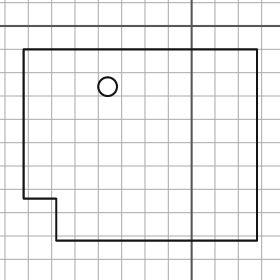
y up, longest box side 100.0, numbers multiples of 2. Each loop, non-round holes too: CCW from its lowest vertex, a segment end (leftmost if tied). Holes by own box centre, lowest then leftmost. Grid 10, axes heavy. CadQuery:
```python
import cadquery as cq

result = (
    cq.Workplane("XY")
    .moveTo(-58.0, -92.0)
    .lineTo(28.0, -92.0)
    .lineTo(28.0, -10.0)
    .lineTo(-72.0, -10.0)
    .lineTo(-72.0, -74.0)
    .lineTo(-58.0, -74.0)
    .close()
    .moveTo(-36.0, -26.0)
    .circle(4.0)
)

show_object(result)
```